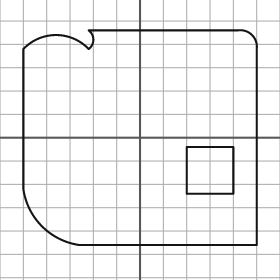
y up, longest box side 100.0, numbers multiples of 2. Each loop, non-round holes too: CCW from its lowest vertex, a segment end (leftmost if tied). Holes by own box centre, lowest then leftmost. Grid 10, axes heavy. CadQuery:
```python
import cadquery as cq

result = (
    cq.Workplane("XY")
    .moveTo(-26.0, -46.0)
    .lineTo(50.0, -46.0)
    .lineTo(50.0, 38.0)
    .threePointArc((48.0, 44.0), (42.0, 46.0))
    .lineTo(-22.0, 46.0)
    .threePointArc((-20.0, 42.0), (-22.0, 38.0))
    .threePointArc((-36.0, 44.0), (-50.0, 38.0))
    .lineTo(-50.0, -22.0)
    .threePointArc((-42.0, -38.0), (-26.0, -46.0))
    .close()
    .moveTo(20.0, -24.0)
    .lineTo(40.0, -24.0)
    .lineTo(40.0, -4.0)
    .lineTo(20.0, -4.0)
    .close()
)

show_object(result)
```